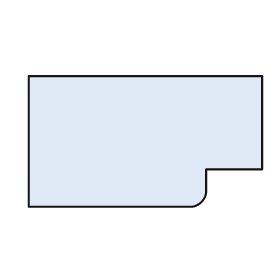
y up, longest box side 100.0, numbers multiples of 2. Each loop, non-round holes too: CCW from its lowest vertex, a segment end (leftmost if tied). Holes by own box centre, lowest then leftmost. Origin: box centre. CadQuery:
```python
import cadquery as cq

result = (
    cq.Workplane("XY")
    .moveTo(-50.0, -28.0)
    .lineTo(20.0, -28.0)
    .threePointArc((24.0, -26.0), (26.0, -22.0))
    .lineTo(26.0, -12.0)
    .lineTo(50.0, -12.0)
    .lineTo(50.0, 28.0)
    .lineTo(-50.0, 28.0)
    .close()
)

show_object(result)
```